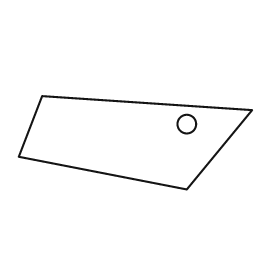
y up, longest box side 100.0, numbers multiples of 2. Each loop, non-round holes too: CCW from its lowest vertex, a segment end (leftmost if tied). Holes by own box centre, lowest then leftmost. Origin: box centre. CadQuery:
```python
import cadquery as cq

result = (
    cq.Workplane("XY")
    .moveTo(22.0, -20.0)
    .lineTo(50.0, 14.0)
    .lineTo(-40.0, 20.0)
    .lineTo(-50.0, -6.0)
    .close()
    .moveTo(22.0, 8.0)
    .circle(4.0)
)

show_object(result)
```